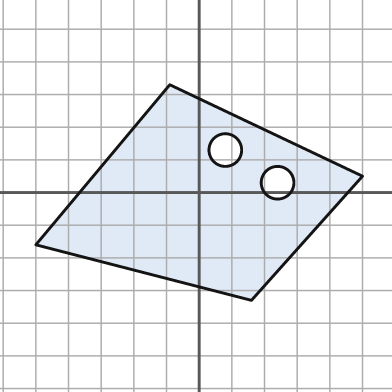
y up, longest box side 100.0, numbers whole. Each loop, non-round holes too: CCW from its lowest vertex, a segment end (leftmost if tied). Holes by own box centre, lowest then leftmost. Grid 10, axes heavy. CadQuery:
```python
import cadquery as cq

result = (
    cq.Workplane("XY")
    .moveTo(16.0, -33.0)
    .lineTo(50.0, 5.0)
    .lineTo(-9.0, 33.0)
    .lineTo(-50.0, -16.0)
    .close()
    .moveTo(24.0, 3.0)
    .circle(5.0)
    .moveTo(8.0, 13.0)
    .circle(5.0)
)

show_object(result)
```